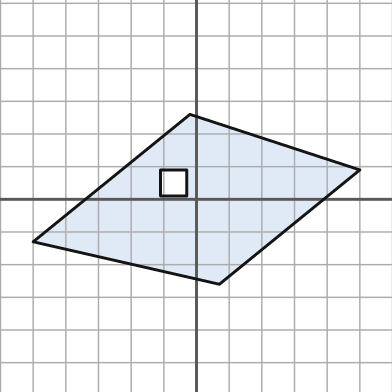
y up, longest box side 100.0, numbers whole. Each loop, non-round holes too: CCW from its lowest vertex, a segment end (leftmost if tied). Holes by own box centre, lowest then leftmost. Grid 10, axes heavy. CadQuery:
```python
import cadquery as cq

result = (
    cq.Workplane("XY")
    .moveTo(7.0, -26.0)
    .lineTo(50.0, 9.0)
    .lineTo(-2.0, 26.0)
    .lineTo(-50.0, -13.0)
    .close()
    .moveTo(-11.0, 1.0)
    .lineTo(-3.0, 1.0)
    .lineTo(-3.0, 9.0)
    .lineTo(-11.0, 9.0)
    .close()
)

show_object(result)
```